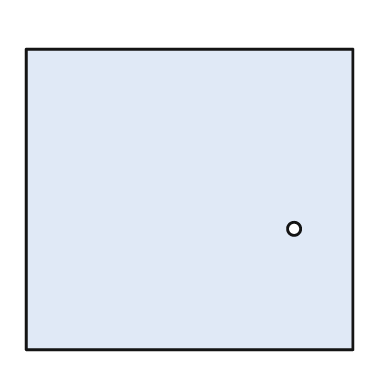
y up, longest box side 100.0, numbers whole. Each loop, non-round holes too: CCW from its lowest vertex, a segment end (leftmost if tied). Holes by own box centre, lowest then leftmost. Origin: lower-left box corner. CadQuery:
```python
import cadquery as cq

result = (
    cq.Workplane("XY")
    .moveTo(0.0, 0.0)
    .lineTo(100.0, 0.0)
    .lineTo(100.0, 92.0)
    .lineTo(0.0, 92.0)
    .close()
    .moveTo(82.0, 37.0)
    .circle(2.0)
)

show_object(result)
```